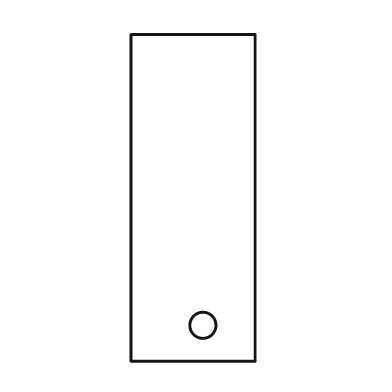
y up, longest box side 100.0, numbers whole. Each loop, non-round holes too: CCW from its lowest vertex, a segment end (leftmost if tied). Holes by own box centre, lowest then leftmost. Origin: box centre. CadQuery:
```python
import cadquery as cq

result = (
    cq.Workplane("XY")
    .moveTo(-19.0, -50.0)
    .lineTo(19.0, -50.0)
    .lineTo(19.0, 50.0)
    .lineTo(-19.0, 50.0)
    .close()
    .moveTo(3.0, -39.0)
    .circle(4.0)
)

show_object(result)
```